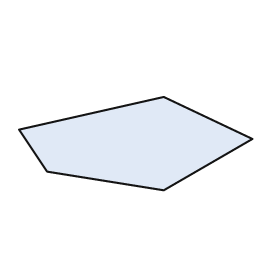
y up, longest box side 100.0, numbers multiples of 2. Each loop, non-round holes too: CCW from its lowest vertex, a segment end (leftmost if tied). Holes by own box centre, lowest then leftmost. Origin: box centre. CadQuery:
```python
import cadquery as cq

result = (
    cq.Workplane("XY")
    .moveTo(12.0, -20.0)
    .lineTo(50.0, 2.0)
    .lineTo(12.0, 20.0)
    .lineTo(-50.0, 6.0)
    .lineTo(-38.0, -12.0)
    .close()
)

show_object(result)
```